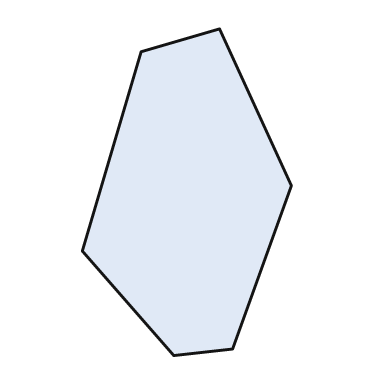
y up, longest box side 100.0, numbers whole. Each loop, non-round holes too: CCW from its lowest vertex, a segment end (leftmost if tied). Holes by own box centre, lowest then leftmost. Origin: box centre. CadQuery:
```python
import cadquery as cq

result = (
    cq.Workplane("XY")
    .moveTo(-4.0, -50.0)
    .lineTo(14.0, -48.0)
    .lineTo(32.0, 2.0)
    .lineTo(10.0, 50.0)
    .lineTo(-14.0, 43.0)
    .lineTo(-32.0, -18.0)
    .close()
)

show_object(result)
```